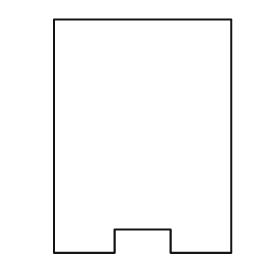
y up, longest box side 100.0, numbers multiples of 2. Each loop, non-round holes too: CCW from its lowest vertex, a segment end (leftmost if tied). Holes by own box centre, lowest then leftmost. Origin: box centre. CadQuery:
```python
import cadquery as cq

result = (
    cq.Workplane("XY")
    .moveTo(-38.0, -50.0)
    .lineTo(-12.0, -50.0)
    .lineTo(-12.0, -40.0)
    .lineTo(12.0, -40.0)
    .lineTo(12.0, -50.0)
    .lineTo(38.0, -50.0)
    .lineTo(38.0, 50.0)
    .lineTo(-38.0, 50.0)
    .close()
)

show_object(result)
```